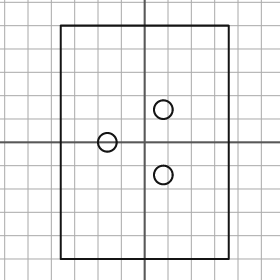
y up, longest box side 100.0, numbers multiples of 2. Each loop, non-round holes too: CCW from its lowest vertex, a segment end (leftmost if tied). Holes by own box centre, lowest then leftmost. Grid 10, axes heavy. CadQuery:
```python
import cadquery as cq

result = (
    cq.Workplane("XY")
    .moveTo(-36.0, -50.0)
    .lineTo(36.0, -50.0)
    .lineTo(36.0, 50.0)
    .lineTo(-36.0, 50.0)
    .close()
    .moveTo(8.0, -14.0)
    .circle(4.0)
    .moveTo(-16.0, 0.0)
    .circle(4.0)
    .moveTo(8.0, 14.0)
    .circle(4.0)
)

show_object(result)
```